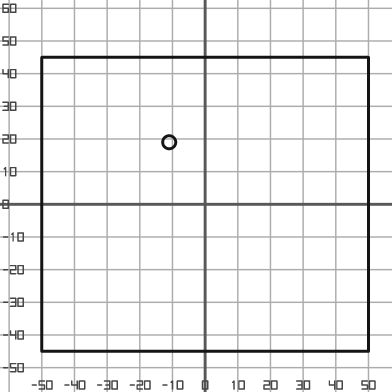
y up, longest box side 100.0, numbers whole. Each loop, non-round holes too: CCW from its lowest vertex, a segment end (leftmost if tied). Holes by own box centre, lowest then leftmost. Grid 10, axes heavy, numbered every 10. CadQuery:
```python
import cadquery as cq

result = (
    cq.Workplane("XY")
    .moveTo(-50.0, -45.0)
    .lineTo(50.0, -45.0)
    .lineTo(50.0, 45.0)
    .lineTo(-50.0, 45.0)
    .close()
    .moveTo(-11.0, 19.0)
    .circle(2.0)
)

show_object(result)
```